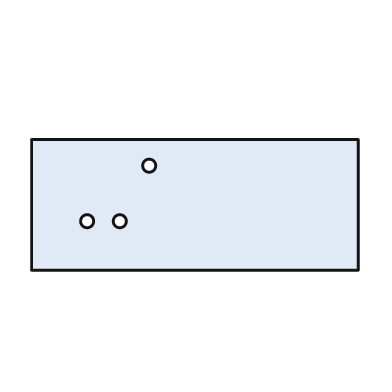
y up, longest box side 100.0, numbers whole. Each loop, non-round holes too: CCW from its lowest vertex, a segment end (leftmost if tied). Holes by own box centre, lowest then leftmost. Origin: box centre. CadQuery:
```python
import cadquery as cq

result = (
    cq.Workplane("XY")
    .moveTo(-50.0, -20.0)
    .lineTo(50.0, -20.0)
    .lineTo(50.0, 20.0)
    .lineTo(-50.0, 20.0)
    .close()
    .moveTo(-33.0, -5.0)
    .circle(2.0)
    .moveTo(-23.0, -5.0)
    .circle(2.0)
    .moveTo(-14.0, 12.0)
    .circle(2.0)
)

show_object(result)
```